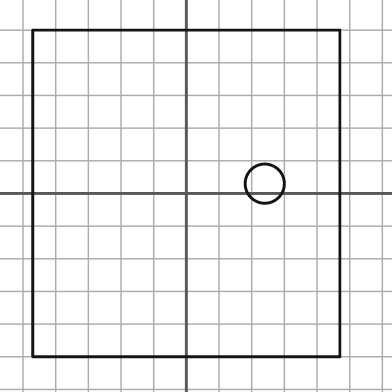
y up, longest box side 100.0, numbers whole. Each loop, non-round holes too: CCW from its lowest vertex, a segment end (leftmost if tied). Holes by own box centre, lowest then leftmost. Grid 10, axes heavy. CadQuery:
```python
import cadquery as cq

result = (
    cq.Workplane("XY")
    .moveTo(-47.0, -50.0)
    .lineTo(47.0, -50.0)
    .lineTo(47.0, 50.0)
    .lineTo(-47.0, 50.0)
    .close()
    .moveTo(24.0, 3.0)
    .circle(6.0)
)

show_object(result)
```